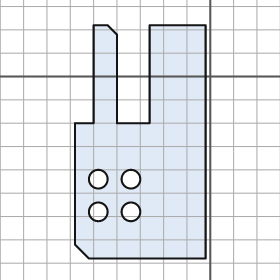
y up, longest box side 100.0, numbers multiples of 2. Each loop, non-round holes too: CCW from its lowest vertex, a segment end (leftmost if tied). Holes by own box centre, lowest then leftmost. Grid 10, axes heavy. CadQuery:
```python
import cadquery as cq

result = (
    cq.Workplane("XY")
    .moveTo(-52.0, -78.0)
    .lineTo(-2.0, -78.0)
    .lineTo(-2.0, 22.0)
    .lineTo(-26.0, 22.0)
    .lineTo(-26.0, -20.0)
    .lineTo(-40.0, -20.0)
    .lineTo(-40.0, 18.0)
    .lineTo(-44.0, 22.0)
    .lineTo(-50.0, 22.0)
    .lineTo(-50.0, -20.0)
    .lineTo(-58.0, -20.0)
    .lineTo(-58.0, -72.0)
    .close()
    .moveTo(-48.0, -58.0)
    .circle(4.0)
    .moveTo(-34.0, -58.0)
    .circle(4.0)
    .moveTo(-48.0, -44.0)
    .circle(4.0)
    .moveTo(-34.0, -44.0)
    .circle(4.0)
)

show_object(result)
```